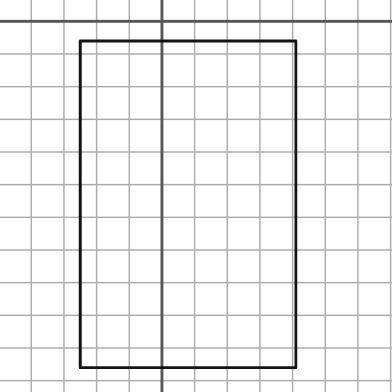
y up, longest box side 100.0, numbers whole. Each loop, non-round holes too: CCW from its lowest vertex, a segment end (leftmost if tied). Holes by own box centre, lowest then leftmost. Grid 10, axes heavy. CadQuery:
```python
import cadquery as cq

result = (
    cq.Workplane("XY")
    .moveTo(-25.0, -106.0)
    .lineTo(41.0, -106.0)
    .lineTo(41.0, -6.0)
    .lineTo(-25.0, -6.0)
    .close()
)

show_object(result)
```